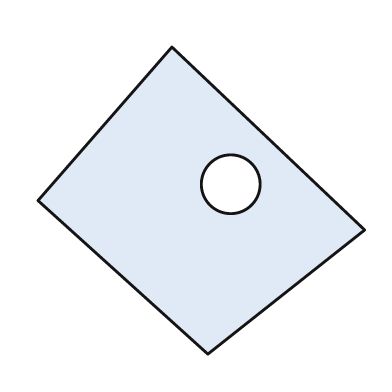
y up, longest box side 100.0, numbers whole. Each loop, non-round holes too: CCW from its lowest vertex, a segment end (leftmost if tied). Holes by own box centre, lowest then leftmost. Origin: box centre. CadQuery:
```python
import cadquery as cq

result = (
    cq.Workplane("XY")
    .moveTo(2.0, -47.0)
    .lineTo(50.0, -9.0)
    .lineTo(-9.0, 47.0)
    .lineTo(-50.0, 0.0)
    .close()
    .moveTo(9.0, 5.0)
    .circle(9.0)
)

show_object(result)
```